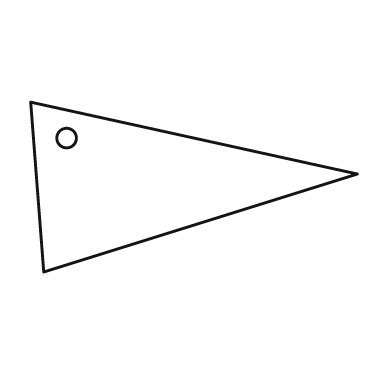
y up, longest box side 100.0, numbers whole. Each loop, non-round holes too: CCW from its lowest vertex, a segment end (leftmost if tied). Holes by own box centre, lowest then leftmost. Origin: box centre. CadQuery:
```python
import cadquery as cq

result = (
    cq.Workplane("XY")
    .moveTo(-46.0, -26.0)
    .lineTo(50.0, 4.0)
    .lineTo(-50.0, 26.0)
    .close()
    .moveTo(-39.0, 15.0)
    .circle(3.0)
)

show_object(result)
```